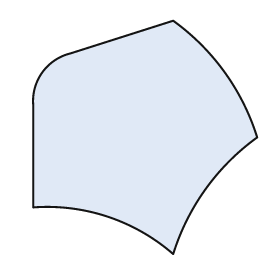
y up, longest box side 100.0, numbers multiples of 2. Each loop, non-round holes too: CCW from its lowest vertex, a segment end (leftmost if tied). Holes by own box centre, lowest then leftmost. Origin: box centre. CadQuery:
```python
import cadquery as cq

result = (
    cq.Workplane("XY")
    .moveTo(12.0, -50.0)
    .threePointArc((26.0, -22.0), (48.0, 0.0))
    .threePointArc((34.0, 28.0), (12.0, 50.0))
    .lineTo(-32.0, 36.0)
    .threePointArc((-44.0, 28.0), (-48.0, 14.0))
    .lineTo(-48.0, -30.0)
    .threePointArc((-16.0, -34.0), (12.0, -50.0))
    .close()
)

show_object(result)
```